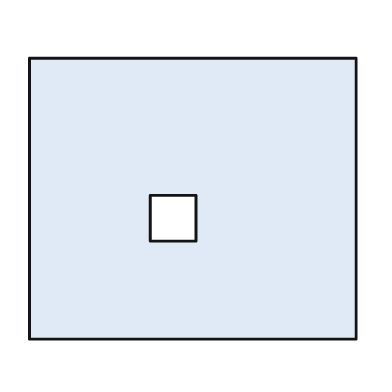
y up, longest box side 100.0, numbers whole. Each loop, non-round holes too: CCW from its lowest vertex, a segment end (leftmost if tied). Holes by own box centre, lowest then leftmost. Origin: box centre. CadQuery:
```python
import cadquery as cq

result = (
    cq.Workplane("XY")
    .moveTo(-50.0, -43.0)
    .lineTo(50.0, -43.0)
    .lineTo(50.0, 43.0)
    .lineTo(-50.0, 43.0)
    .close()
    .moveTo(-13.0, -13.0)
    .lineTo(1.0, -13.0)
    .lineTo(1.0, 1.0)
    .lineTo(-13.0, 1.0)
    .close()
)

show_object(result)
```